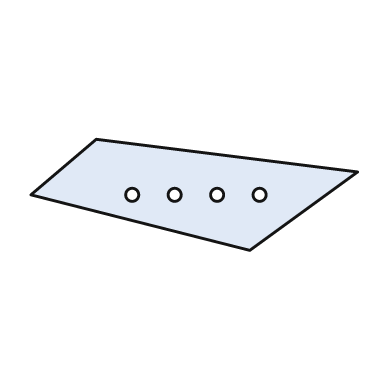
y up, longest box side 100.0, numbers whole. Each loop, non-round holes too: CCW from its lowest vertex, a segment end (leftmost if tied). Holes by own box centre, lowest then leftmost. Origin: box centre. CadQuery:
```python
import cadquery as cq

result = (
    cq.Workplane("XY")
    .moveTo(17.0, -17.0)
    .lineTo(50.0, 7.0)
    .lineTo(-30.0, 17.0)
    .lineTo(-50.0, 0.0)
    .close()
    .moveTo(-19.0, 0.0)
    .circle(2.0)
    .moveTo(-6.0, 0.0)
    .circle(2.0)
    .moveTo(7.0, 0.0)
    .circle(2.0)
    .moveTo(20.0, 0.0)
    .circle(2.0)
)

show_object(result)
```